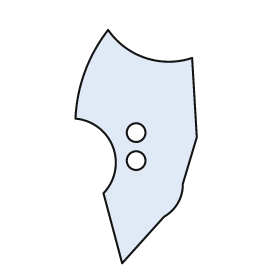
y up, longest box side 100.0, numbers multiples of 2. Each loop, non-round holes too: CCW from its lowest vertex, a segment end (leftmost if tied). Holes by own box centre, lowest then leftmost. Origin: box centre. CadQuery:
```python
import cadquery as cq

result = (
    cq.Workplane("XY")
    .moveTo(-6.0, -50.0)
    .lineTo(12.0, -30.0)
    .threePointArc((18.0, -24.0), (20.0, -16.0))
    .lineTo(26.0, 4.0)
    .lineTo(24.0, 38.0)
    .threePointArc((4.0, 38.0), (-12.0, 50.0))
    .threePointArc((-22.0, 32.0), (-26.0, 12.0))
    .threePointArc((-10.0, 0.0), (-14.0, -20.0))
    .close()
    .moveTo(0.0, -6.0)
    .circle(4.0)
    .moveTo(0.0, 6.0)
    .circle(4.0)
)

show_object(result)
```